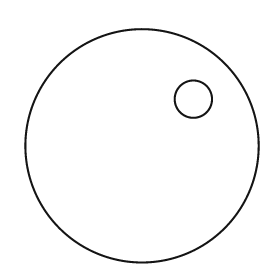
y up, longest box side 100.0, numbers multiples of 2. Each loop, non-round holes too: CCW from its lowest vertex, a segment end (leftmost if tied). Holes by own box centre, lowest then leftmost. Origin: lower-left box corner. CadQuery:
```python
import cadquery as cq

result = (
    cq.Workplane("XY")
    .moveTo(50.0, 50.0)
    .circle(50.0)
    .moveTo(72.0, 70.0)
    .circle(8.0)
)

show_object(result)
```